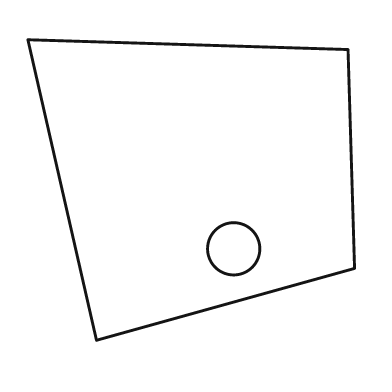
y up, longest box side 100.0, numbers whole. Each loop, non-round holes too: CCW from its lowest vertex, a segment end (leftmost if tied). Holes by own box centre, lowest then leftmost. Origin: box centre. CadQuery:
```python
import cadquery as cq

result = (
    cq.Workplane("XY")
    .moveTo(-29.0, -46.0)
    .lineTo(50.0, -24.0)
    .lineTo(48.0, 43.0)
    .lineTo(-50.0, 46.0)
    .close()
    .moveTo(13.0, -18.0)
    .circle(8.0)
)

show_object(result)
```